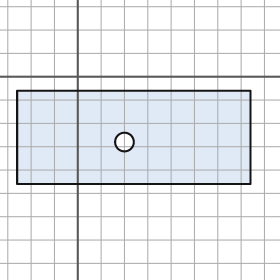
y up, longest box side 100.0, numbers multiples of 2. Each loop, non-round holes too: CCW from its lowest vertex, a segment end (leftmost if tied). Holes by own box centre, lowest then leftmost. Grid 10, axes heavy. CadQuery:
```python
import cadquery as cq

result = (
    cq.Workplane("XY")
    .moveTo(-26.0, -46.0)
    .lineTo(74.0, -46.0)
    .lineTo(74.0, -6.0)
    .lineTo(-26.0, -6.0)
    .close()
    .moveTo(20.0, -28.0)
    .circle(4.0)
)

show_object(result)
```